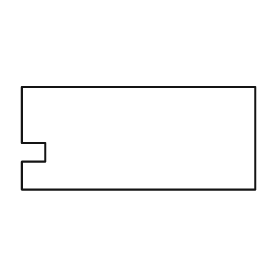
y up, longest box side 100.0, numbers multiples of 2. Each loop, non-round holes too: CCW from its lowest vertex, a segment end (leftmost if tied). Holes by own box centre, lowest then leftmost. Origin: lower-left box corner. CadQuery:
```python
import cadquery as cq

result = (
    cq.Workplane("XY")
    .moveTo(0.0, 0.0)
    .lineTo(100.0, 0.0)
    .lineTo(100.0, 44.0)
    .lineTo(0.0, 44.0)
    .lineTo(0.0, 20.0)
    .lineTo(10.0, 20.0)
    .lineTo(10.0, 12.0)
    .lineTo(0.0, 12.0)
    .close()
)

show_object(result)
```